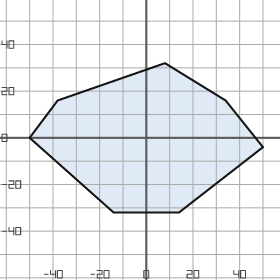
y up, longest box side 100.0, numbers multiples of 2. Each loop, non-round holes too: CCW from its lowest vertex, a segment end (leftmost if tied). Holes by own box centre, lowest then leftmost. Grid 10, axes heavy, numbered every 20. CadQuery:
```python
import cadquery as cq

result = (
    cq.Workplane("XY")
    .moveTo(-14.0, -32.0)
    .lineTo(14.0, -32.0)
    .lineTo(50.0, -4.0)
    .lineTo(34.0, 16.0)
    .lineTo(8.0, 32.0)
    .lineTo(-38.0, 16.0)
    .lineTo(-50.0, 0.0)
    .close()
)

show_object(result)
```